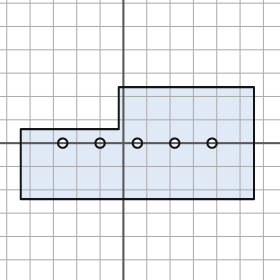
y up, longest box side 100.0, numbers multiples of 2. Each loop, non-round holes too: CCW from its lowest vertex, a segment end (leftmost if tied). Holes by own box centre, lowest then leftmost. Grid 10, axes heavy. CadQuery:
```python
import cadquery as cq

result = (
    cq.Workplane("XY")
    .moveTo(-44.0, -24.0)
    .lineTo(56.0, -24.0)
    .lineTo(56.0, 24.0)
    .lineTo(-2.0, 24.0)
    .lineTo(-2.0, 6.0)
    .lineTo(-44.0, 6.0)
    .close()
    .moveTo(-26.0, 0.0)
    .circle(2.0)
    .moveTo(-10.0, 0.0)
    .circle(2.0)
    .moveTo(6.0, 0.0)
    .circle(2.0)
    .moveTo(22.0, 0.0)
    .circle(2.0)
    .moveTo(38.0, 0.0)
    .circle(2.0)
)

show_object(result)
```